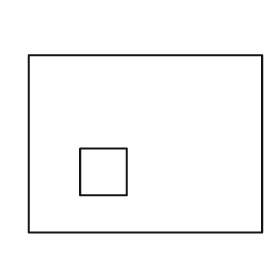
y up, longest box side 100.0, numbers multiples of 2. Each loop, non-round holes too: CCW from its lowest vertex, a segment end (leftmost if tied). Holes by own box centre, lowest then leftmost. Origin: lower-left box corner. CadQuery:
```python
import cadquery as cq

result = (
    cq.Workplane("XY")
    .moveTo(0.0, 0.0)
    .lineTo(100.0, 0.0)
    .lineTo(100.0, 76.0)
    .lineTo(0.0, 76.0)
    .close()
    .moveTo(22.0, 16.0)
    .lineTo(42.0, 16.0)
    .lineTo(42.0, 36.0)
    .lineTo(22.0, 36.0)
    .close()
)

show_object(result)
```